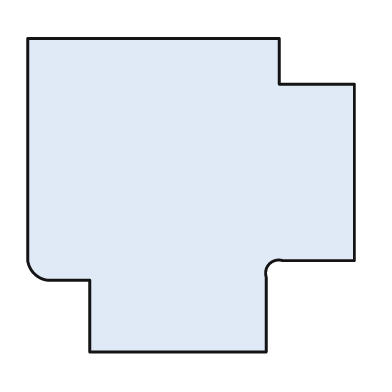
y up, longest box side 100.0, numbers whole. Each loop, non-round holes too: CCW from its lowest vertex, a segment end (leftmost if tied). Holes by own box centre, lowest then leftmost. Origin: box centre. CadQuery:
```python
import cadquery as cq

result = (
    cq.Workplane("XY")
    .moveTo(-31.0, -48.0)
    .lineTo(23.0, -48.0)
    .lineTo(23.0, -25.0)
    .threePointArc((24.0, -21.0), (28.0, -20.0))
    .lineTo(50.0, -20.0)
    .lineTo(50.0, 34.0)
    .lineTo(27.0, 34.0)
    .lineTo(27.0, 48.0)
    .lineTo(-50.0, 48.0)
    .lineTo(-50.0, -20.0)
    .threePointArc((-48.0, -24.0), (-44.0, -26.0))
    .lineTo(-31.0, -26.0)
    .close()
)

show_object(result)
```